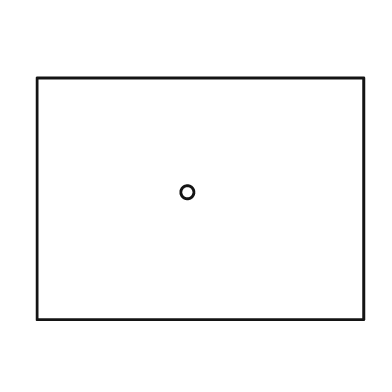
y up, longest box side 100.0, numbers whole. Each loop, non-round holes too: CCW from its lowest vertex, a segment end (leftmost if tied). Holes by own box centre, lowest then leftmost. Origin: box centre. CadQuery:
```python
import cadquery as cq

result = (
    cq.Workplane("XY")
    .moveTo(-50.0, -37.0)
    .lineTo(50.0, -37.0)
    .lineTo(50.0, 37.0)
    .lineTo(-50.0, 37.0)
    .close()
    .moveTo(-4.0, 2.0)
    .circle(2.0)
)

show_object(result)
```